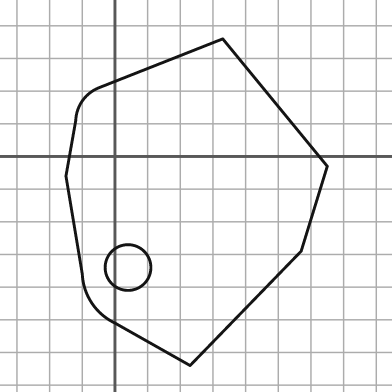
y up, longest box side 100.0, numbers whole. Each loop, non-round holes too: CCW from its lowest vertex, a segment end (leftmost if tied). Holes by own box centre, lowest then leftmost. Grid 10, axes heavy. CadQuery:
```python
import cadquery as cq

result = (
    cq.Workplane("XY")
    .moveTo(23.0, -64.0)
    .lineTo(57.0, -29.0)
    .lineTo(65.0, -3.0)
    .lineTo(33.0, 36.0)
    .lineTo(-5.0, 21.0)
    .threePointArc((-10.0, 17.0), (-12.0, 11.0))
    .lineTo(-15.0, -6.0)
    .lineTo(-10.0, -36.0)
    .threePointArc((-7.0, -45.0), (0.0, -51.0))
    .close()
    .moveTo(4.0, -34.0)
    .circle(7.0)
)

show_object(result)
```